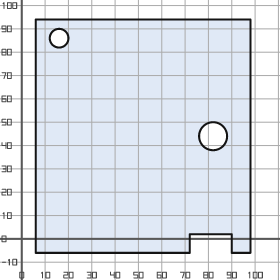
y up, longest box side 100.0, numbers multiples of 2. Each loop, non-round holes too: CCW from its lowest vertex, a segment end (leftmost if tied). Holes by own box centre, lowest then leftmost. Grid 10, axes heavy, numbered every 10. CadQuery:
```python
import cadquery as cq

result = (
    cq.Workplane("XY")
    .moveTo(6.0, -6.0)
    .lineTo(72.0, -6.0)
    .lineTo(72.0, 2.0)
    .lineTo(90.0, 2.0)
    .lineTo(90.0, -6.0)
    .lineTo(98.0, -6.0)
    .lineTo(98.0, 94.0)
    .lineTo(6.0, 94.0)
    .close()
    .moveTo(82.0, 44.0)
    .circle(6.0)
    .moveTo(16.0, 86.0)
    .circle(4.0)
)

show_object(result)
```